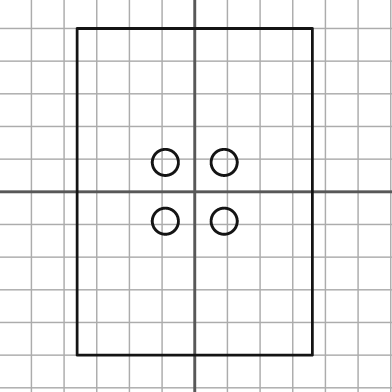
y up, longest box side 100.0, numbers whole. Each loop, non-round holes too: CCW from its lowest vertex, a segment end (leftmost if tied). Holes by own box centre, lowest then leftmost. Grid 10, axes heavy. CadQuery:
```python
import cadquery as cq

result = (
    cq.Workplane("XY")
    .moveTo(-36.0, -50.0)
    .lineTo(36.0, -50.0)
    .lineTo(36.0, 50.0)
    .lineTo(-36.0, 50.0)
    .close()
    .moveTo(-9.0, -9.0)
    .circle(4.0)
    .moveTo(9.0, -9.0)
    .circle(4.0)
    .moveTo(-9.0, 9.0)
    .circle(4.0)
    .moveTo(9.0, 9.0)
    .circle(4.0)
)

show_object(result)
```